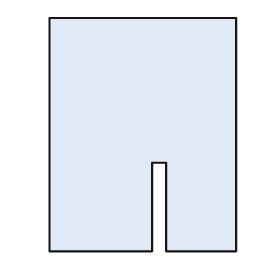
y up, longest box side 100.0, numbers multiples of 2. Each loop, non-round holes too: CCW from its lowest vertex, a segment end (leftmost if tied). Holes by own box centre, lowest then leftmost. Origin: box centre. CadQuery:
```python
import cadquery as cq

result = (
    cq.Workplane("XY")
    .moveTo(-40.0, -50.0)
    .lineTo(4.0, -50.0)
    .lineTo(4.0, -12.0)
    .lineTo(10.0, -12.0)
    .lineTo(10.0, -50.0)
    .lineTo(40.0, -50.0)
    .lineTo(40.0, 50.0)
    .lineTo(-40.0, 50.0)
    .close()
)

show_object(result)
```